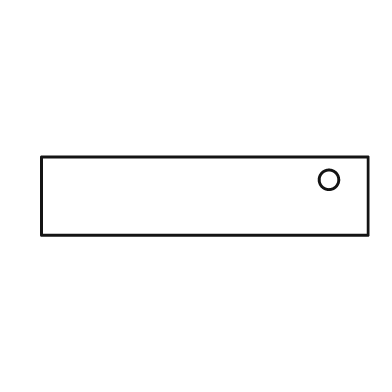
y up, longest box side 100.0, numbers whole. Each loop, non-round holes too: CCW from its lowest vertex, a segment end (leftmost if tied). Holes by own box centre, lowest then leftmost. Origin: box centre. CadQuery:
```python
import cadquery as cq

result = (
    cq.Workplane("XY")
    .moveTo(-50.0, -12.0)
    .lineTo(50.0, -12.0)
    .lineTo(50.0, 12.0)
    .lineTo(-50.0, 12.0)
    .close()
    .moveTo(38.0, 5.0)
    .circle(3.0)
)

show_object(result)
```